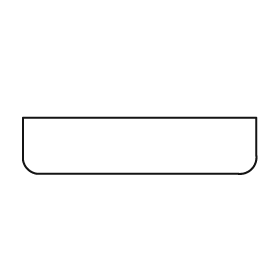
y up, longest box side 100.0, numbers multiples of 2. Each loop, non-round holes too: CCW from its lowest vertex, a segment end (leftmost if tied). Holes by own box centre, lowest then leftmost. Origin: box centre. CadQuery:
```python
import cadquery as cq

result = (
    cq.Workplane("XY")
    .moveTo(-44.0, -12.0)
    .lineTo(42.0, -12.0)
    .threePointArc((48.0, -10.0), (50.0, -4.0))
    .lineTo(50.0, 12.0)
    .lineTo(-50.0, 12.0)
    .lineTo(-50.0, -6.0)
    .threePointArc((-48.0, -10.0), (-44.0, -12.0))
    .close()
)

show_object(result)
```